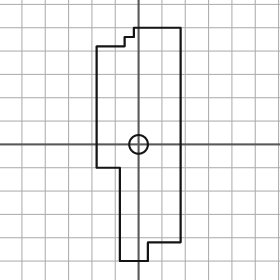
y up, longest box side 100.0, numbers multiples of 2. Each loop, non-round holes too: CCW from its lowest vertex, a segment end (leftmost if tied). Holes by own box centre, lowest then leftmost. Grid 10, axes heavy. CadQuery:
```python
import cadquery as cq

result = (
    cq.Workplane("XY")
    .moveTo(-8.0, -50.0)
    .lineTo(4.0, -50.0)
    .lineTo(4.0, -42.0)
    .lineTo(18.0, -42.0)
    .lineTo(18.0, 50.0)
    .lineTo(-2.0, 50.0)
    .lineTo(-2.0, 46.0)
    .lineTo(-6.0, 46.0)
    .lineTo(-6.0, 42.0)
    .lineTo(-18.0, 42.0)
    .lineTo(-18.0, -10.0)
    .lineTo(-8.0, -10.0)
    .close()
    .moveTo(0.0, 0.0)
    .circle(4.0)
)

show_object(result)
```